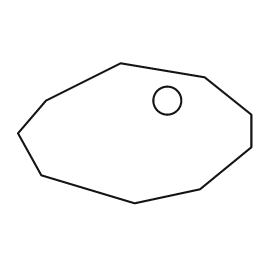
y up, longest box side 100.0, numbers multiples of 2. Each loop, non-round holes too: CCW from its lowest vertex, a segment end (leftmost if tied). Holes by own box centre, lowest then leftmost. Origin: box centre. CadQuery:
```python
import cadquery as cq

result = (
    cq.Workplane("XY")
    .moveTo(0.0, -30.0)
    .lineTo(28.0, -24.0)
    .lineTo(50.0, -6.0)
    .lineTo(50.0, 8.0)
    .lineTo(30.0, 24.0)
    .lineTo(-6.0, 30.0)
    .lineTo(-38.0, 14.0)
    .lineTo(-50.0, 0.0)
    .lineTo(-40.0, -18.0)
    .close()
    .moveTo(14.0, 14.0)
    .circle(6.0)
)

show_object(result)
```